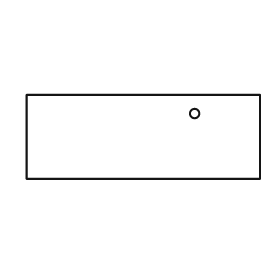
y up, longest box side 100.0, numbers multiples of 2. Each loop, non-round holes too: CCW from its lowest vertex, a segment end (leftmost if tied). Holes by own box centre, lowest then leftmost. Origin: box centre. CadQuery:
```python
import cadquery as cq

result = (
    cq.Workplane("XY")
    .moveTo(-50.0, -18.0)
    .lineTo(50.0, -18.0)
    .lineTo(50.0, 18.0)
    .lineTo(-50.0, 18.0)
    .close()
    .moveTo(22.0, 10.0)
    .circle(2.0)
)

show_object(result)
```